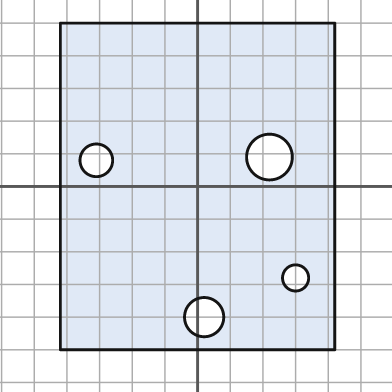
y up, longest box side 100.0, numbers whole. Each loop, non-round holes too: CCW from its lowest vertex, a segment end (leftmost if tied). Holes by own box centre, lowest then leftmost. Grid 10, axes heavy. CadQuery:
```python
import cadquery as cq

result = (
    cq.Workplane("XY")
    .moveTo(-42.0, -50.0)
    .lineTo(42.0, -50.0)
    .lineTo(42.0, 50.0)
    .lineTo(-42.0, 50.0)
    .close()
    .moveTo(2.0, -40.0)
    .circle(6.0)
    .moveTo(30.0, -28.0)
    .circle(4.0)
    .moveTo(-31.0, 8.0)
    .circle(5.0)
    .moveTo(22.0, 9.0)
    .circle(7.0)
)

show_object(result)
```